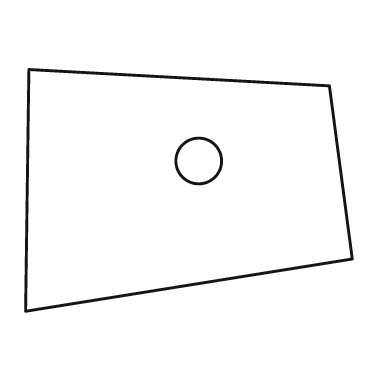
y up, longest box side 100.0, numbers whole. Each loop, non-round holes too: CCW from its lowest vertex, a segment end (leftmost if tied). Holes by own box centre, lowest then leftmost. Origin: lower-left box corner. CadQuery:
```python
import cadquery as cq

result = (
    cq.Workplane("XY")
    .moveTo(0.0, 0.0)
    .lineTo(100.0, 16.0)
    .lineTo(93.0, 69.0)
    .lineTo(1.0, 74.0)
    .close()
    .moveTo(53.0, 46.0)
    .circle(7.0)
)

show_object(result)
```